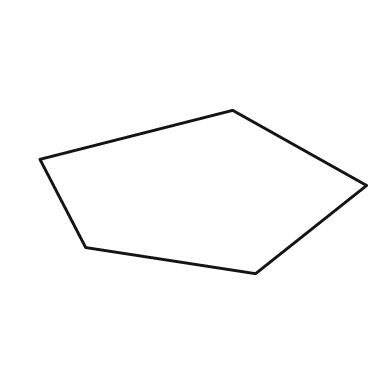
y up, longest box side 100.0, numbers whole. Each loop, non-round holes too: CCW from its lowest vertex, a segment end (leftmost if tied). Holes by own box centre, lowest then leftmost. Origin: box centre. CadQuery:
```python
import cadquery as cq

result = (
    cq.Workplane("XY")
    .moveTo(16.0, -25.0)
    .lineTo(50.0, 2.0)
    .lineTo(9.0, 25.0)
    .lineTo(-50.0, 10.0)
    .lineTo(-36.0, -17.0)
    .close()
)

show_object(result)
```